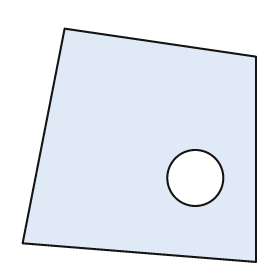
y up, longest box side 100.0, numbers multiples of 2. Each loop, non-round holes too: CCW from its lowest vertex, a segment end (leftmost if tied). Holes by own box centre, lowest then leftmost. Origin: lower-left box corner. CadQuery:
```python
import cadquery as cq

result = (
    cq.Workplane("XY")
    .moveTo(100.0, 0.0)
    .lineTo(100.0, 88.0)
    .lineTo(18.0, 100.0)
    .lineTo(0.0, 8.0)
    .close()
    .moveTo(74.0, 36.0)
    .circle(12.0)
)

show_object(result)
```